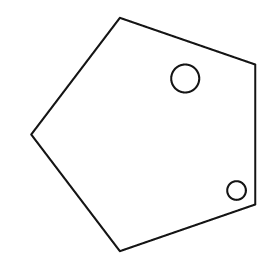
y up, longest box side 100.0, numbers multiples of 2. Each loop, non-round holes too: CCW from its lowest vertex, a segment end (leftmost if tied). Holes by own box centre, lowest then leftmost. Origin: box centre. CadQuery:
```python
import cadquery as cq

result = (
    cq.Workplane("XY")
    .moveTo(-10.0, -50.0)
    .lineTo(48.0, -30.0)
    .lineTo(48.0, 30.0)
    .lineTo(-10.0, 50.0)
    .lineTo(-48.0, 0.0)
    .close()
    .moveTo(40.0, -24.0)
    .circle(4.0)
    .moveTo(18.0, 24.0)
    .circle(6.0)
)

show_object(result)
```